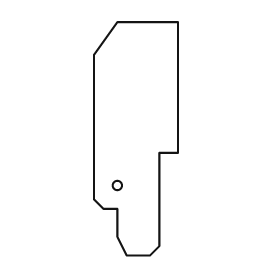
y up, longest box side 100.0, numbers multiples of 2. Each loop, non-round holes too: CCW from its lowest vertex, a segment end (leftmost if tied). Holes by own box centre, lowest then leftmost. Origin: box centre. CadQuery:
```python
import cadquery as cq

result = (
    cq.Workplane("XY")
    .moveTo(-4.0, -50.0)
    .lineTo(6.0, -50.0)
    .lineTo(10.0, -46.0)
    .lineTo(10.0, -6.0)
    .lineTo(18.0, -6.0)
    .lineTo(18.0, 50.0)
    .lineTo(-8.0, 50.0)
    .lineTo(-18.0, 36.0)
    .lineTo(-18.0, -26.0)
    .lineTo(-14.0, -30.0)
    .lineTo(-8.0, -30.0)
    .lineTo(-8.0, -42.0)
    .close()
    .moveTo(-8.0, -20.0)
    .circle(2.0)
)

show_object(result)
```